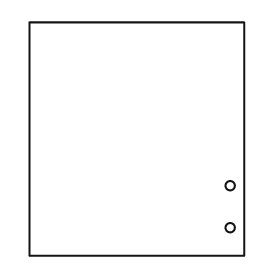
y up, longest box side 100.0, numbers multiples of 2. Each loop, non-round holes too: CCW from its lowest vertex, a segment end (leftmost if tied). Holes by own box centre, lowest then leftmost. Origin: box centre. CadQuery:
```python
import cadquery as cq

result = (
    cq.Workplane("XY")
    .moveTo(-46.0, -50.0)
    .lineTo(46.0, -50.0)
    .lineTo(46.0, 50.0)
    .lineTo(-46.0, 50.0)
    .close()
    .moveTo(40.0, -38.0)
    .circle(2.0)
    .moveTo(40.0, -20.0)
    .circle(2.0)
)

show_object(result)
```